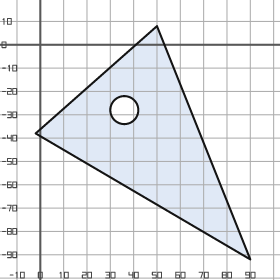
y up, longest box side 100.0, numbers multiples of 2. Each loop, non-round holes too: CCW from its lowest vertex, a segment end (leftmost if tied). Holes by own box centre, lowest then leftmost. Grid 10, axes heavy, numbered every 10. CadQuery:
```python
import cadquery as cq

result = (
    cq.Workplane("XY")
    .moveTo(90.0, -92.0)
    .lineTo(50.0, 8.0)
    .lineTo(-2.0, -38.0)
    .close()
    .moveTo(36.0, -28.0)
    .circle(6.0)
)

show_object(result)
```